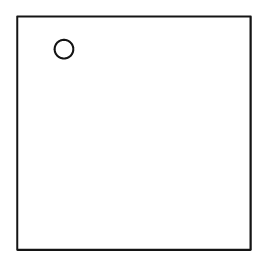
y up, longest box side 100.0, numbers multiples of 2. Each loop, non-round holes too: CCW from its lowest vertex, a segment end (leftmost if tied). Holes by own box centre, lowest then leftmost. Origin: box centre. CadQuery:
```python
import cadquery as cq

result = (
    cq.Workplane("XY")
    .moveTo(-50.0, -50.0)
    .lineTo(50.0, -50.0)
    .lineTo(50.0, 50.0)
    .lineTo(-50.0, 50.0)
    .close()
    .moveTo(-30.0, 36.0)
    .circle(4.0)
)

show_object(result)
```